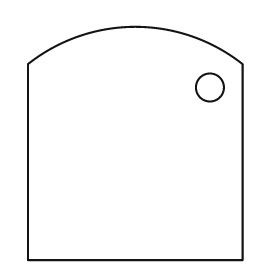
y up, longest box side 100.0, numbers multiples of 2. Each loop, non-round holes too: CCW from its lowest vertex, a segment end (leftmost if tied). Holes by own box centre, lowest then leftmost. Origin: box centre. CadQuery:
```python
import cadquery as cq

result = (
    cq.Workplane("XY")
    .moveTo(-46.0, -50.0)
    .lineTo(46.0, -50.0)
    .lineTo(46.0, 34.0)
    .threePointArc((0.0, 50.0), (-46.0, 34.0))
    .close()
    .moveTo(32.0, 24.0)
    .circle(6.0)
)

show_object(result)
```